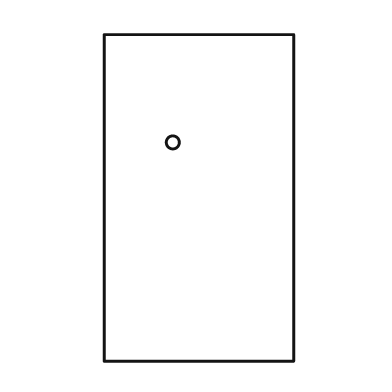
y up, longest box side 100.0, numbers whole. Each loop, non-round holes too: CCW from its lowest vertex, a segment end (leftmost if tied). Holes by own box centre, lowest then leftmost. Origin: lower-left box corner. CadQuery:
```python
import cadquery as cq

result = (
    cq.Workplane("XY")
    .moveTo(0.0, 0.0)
    .lineTo(58.0, 0.0)
    .lineTo(58.0, 100.0)
    .lineTo(0.0, 100.0)
    .close()
    .moveTo(21.0, 67.0)
    .circle(2.0)
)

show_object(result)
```